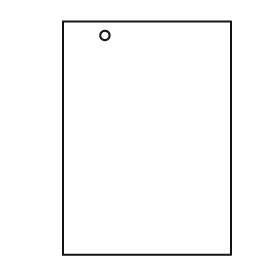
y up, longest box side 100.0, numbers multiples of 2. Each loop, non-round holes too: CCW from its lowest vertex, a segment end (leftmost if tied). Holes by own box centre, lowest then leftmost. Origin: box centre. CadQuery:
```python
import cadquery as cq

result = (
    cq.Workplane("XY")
    .moveTo(-36.0, -50.0)
    .lineTo(36.0, -50.0)
    .lineTo(36.0, 50.0)
    .lineTo(-36.0, 50.0)
    .close()
    .moveTo(-18.0, 44.0)
    .circle(2.0)
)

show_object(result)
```